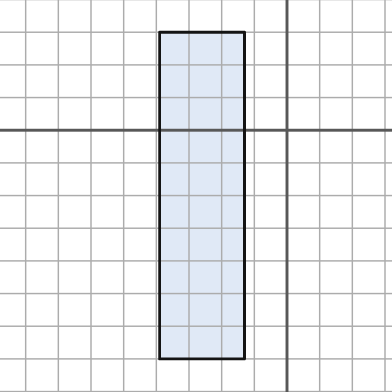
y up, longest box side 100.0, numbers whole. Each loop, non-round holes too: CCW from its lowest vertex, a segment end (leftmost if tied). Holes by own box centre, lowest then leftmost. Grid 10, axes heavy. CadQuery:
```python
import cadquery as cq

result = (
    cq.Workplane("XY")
    .moveTo(-39.0, -70.0)
    .lineTo(-13.0, -70.0)
    .lineTo(-13.0, 30.0)
    .lineTo(-39.0, 30.0)
    .close()
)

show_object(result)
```